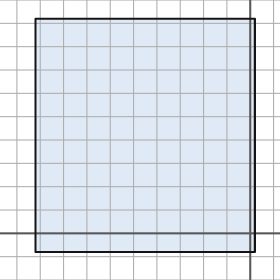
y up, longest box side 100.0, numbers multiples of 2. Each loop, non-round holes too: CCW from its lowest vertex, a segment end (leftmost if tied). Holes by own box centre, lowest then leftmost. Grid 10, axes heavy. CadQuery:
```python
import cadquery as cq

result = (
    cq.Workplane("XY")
    .moveTo(-92.0, -8.0)
    .lineTo(2.0, -8.0)
    .lineTo(2.0, 92.0)
    .lineTo(-92.0, 92.0)
    .close()
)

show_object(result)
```